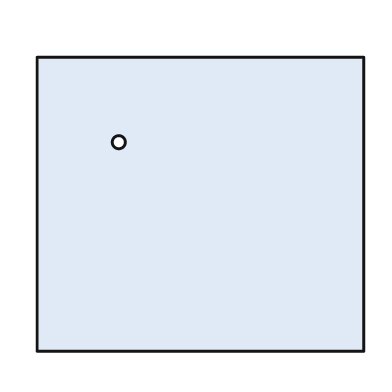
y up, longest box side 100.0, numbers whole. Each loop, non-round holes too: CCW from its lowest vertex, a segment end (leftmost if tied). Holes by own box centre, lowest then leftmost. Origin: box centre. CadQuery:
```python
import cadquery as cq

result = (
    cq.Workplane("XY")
    .moveTo(-50.0, -45.0)
    .lineTo(50.0, -45.0)
    .lineTo(50.0, 45.0)
    .lineTo(-50.0, 45.0)
    .close()
    .moveTo(-25.0, 19.0)
    .circle(2.0)
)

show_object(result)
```